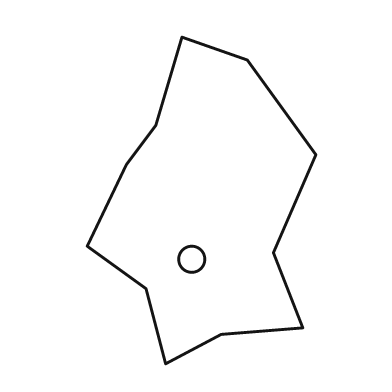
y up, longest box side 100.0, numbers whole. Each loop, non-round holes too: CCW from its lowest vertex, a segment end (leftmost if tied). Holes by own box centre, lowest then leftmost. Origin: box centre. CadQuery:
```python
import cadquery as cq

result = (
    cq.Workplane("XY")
    .moveTo(-11.0, -50.0)
    .lineTo(6.0, -41.0)
    .lineTo(31.0, -39.0)
    .lineTo(22.0, -16.0)
    .lineTo(35.0, 14.0)
    .lineTo(14.0, 43.0)
    .lineTo(-6.0, 50.0)
    .lineTo(-14.0, 23.0)
    .lineTo(-23.0, 11.0)
    .lineTo(-35.0, -14.0)
    .lineTo(-17.0, -27.0)
    .close()
    .moveTo(-3.0, -18.0)
    .circle(4.0)
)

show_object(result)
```